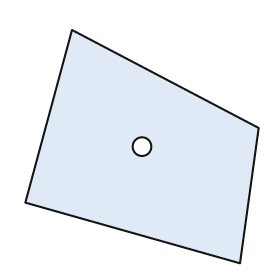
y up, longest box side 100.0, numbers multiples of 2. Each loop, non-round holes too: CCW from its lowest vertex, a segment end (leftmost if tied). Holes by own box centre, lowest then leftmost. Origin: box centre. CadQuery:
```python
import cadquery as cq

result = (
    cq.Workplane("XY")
    .moveTo(42.0, -50.0)
    .lineTo(50.0, 8.0)
    .lineTo(-30.0, 50.0)
    .lineTo(-50.0, -24.0)
    .close()
    .moveTo(0.0, 0.0)
    .circle(4.0)
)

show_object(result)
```